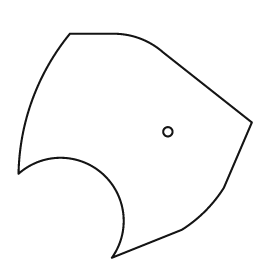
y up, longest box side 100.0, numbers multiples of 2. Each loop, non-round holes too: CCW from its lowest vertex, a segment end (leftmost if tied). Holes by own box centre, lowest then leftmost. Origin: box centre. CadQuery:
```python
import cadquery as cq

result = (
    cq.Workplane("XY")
    .moveTo(-10.0, -48.0)
    .lineTo(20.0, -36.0)
    .threePointArc((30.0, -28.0), (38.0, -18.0))
    .lineTo(50.0, 10.0)
    .lineTo(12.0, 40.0)
    .threePointArc((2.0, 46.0), (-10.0, 48.0))
    .lineTo(-28.0, 48.0)
    .threePointArc((-44.0, 20.0), (-50.0, -12.0))
    .threePointArc((-14.0, -12.0), (-10.0, -48.0))
    .close()
    .moveTo(14.0, 6.0)
    .circle(2.0)
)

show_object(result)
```